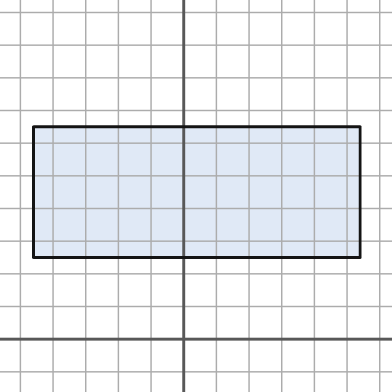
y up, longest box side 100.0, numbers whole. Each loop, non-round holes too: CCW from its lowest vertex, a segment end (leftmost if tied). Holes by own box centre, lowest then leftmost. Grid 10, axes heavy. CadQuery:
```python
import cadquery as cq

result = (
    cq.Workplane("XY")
    .moveTo(-46.0, 25.0)
    .lineTo(54.0, 25.0)
    .lineTo(54.0, 65.0)
    .lineTo(-46.0, 65.0)
    .close()
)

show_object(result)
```